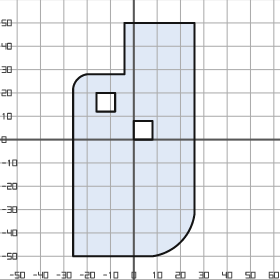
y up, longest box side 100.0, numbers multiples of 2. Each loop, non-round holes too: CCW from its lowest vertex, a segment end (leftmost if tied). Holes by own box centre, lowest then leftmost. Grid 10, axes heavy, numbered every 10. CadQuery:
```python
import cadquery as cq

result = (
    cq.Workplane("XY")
    .moveTo(-26.0, -50.0)
    .lineTo(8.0, -50.0)
    .threePointArc((20.0, -44.0), (26.0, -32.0))
    .lineTo(26.0, 50.0)
    .lineTo(-4.0, 50.0)
    .lineTo(-4.0, 28.0)
    .lineTo(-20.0, 28.0)
    .threePointArc((-24.0, 26.0), (-26.0, 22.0))
    .close()
    .moveTo(0.0, 0.0)
    .lineTo(8.0, 0.0)
    .lineTo(8.0, 8.0)
    .lineTo(0.0, 8.0)
    .close()
    .moveTo(-16.0, 12.0)
    .lineTo(-8.0, 12.0)
    .lineTo(-8.0, 20.0)
    .lineTo(-16.0, 20.0)
    .close()
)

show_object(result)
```